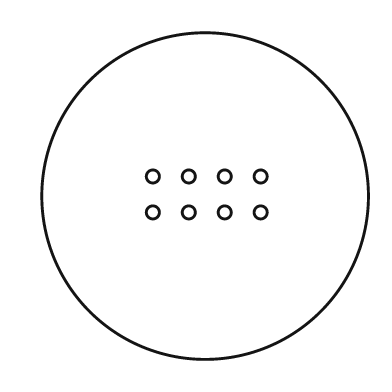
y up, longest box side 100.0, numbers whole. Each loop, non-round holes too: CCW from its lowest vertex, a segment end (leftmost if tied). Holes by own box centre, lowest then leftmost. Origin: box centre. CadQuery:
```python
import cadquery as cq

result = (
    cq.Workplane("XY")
    .moveTo(0.0, 0.0)
    .circle(50.0)
    .moveTo(-16.0, -5.0)
    .circle(2.0)
    .moveTo(-5.0, -5.0)
    .circle(2.0)
    .moveTo(6.0, -5.0)
    .circle(2.0)
    .moveTo(17.0, -5.0)
    .circle(2.0)
    .moveTo(-16.0, 6.0)
    .circle(2.0)
    .moveTo(-5.0, 6.0)
    .circle(2.0)
    .moveTo(6.0, 6.0)
    .circle(2.0)
    .moveTo(17.0, 6.0)
    .circle(2.0)
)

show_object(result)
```